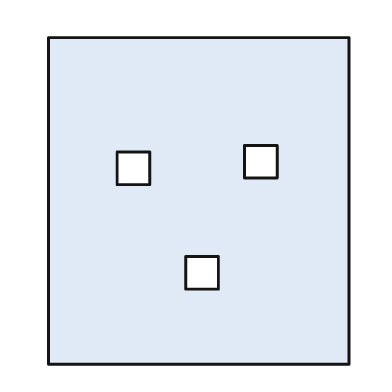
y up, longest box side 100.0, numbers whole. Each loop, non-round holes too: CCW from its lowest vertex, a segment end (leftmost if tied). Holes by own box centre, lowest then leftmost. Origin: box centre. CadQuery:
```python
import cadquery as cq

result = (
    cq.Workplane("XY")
    .moveTo(-46.0, -50.0)
    .lineTo(46.0, -50.0)
    .lineTo(46.0, 50.0)
    .lineTo(-46.0, 50.0)
    .close()
    .moveTo(-4.0, -27.0)
    .lineTo(6.0, -27.0)
    .lineTo(6.0, -17.0)
    .lineTo(-4.0, -17.0)
    .close()
    .moveTo(-25.0, 5.0)
    .lineTo(-15.0, 5.0)
    .lineTo(-15.0, 15.0)
    .lineTo(-25.0, 15.0)
    .close()
    .moveTo(14.0, 7.0)
    .lineTo(24.0, 7.0)
    .lineTo(24.0, 17.0)
    .lineTo(14.0, 17.0)
    .close()
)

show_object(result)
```